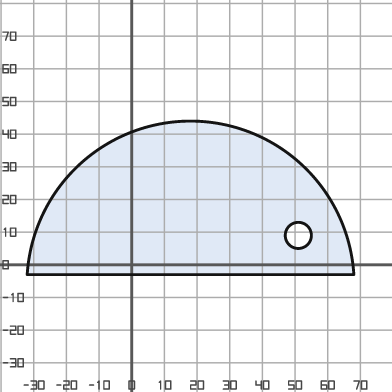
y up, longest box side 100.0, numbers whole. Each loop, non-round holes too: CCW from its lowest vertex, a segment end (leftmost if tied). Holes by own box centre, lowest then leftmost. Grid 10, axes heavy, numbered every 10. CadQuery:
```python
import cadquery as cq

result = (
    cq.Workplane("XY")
    .moveTo(-32.0, -3.0)
    .lineTo(68.0, -3.0)
    .threePointArc((18.0, 44.0), (-32.0, -3.0))
    .close()
    .moveTo(51.0, 9.0)
    .circle(4.0)
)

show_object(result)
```